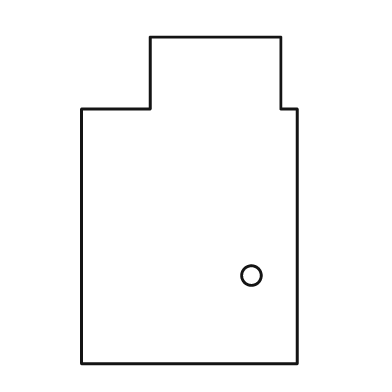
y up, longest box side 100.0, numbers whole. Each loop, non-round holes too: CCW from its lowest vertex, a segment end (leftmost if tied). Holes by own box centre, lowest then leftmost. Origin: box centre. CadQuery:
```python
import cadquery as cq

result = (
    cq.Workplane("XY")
    .moveTo(-33.0, -50.0)
    .lineTo(33.0, -50.0)
    .lineTo(33.0, 28.0)
    .lineTo(28.0, 28.0)
    .lineTo(28.0, 50.0)
    .lineTo(-12.0, 50.0)
    .lineTo(-12.0, 28.0)
    .lineTo(-33.0, 28.0)
    .close()
    .moveTo(19.0, -23.0)
    .circle(3.0)
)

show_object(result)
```